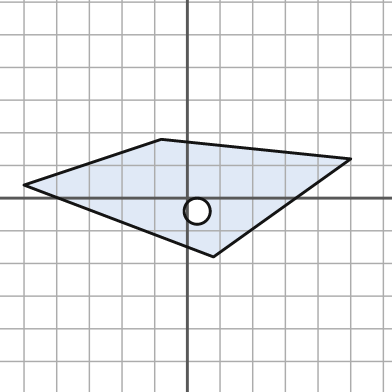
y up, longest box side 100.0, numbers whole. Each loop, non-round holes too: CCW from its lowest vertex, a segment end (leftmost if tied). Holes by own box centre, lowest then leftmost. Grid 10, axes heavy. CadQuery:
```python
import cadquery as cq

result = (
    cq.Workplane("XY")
    .moveTo(8.0, -18.0)
    .lineTo(50.0, 12.0)
    .lineTo(-8.0, 18.0)
    .lineTo(-50.0, 4.0)
    .close()
    .moveTo(3.0, -4.0)
    .circle(4.0)
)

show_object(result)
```